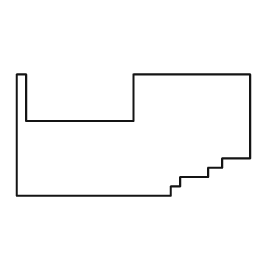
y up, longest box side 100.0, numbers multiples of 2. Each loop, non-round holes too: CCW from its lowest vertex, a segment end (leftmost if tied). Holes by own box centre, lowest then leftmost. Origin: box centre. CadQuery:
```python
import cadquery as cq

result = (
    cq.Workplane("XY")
    .moveTo(-50.0, -26.0)
    .lineTo(16.0, -26.0)
    .lineTo(16.0, -22.0)
    .lineTo(20.0, -22.0)
    .lineTo(20.0, -18.0)
    .lineTo(32.0, -18.0)
    .lineTo(32.0, -14.0)
    .lineTo(38.0, -14.0)
    .lineTo(38.0, -10.0)
    .lineTo(50.0, -10.0)
    .lineTo(50.0, 26.0)
    .lineTo(0.0, 26.0)
    .lineTo(0.0, 6.0)
    .lineTo(-46.0, 6.0)
    .lineTo(-46.0, 26.0)
    .lineTo(-50.0, 26.0)
    .close()
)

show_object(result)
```